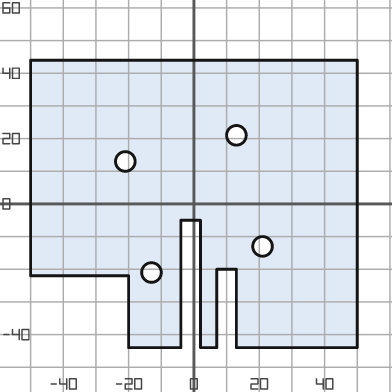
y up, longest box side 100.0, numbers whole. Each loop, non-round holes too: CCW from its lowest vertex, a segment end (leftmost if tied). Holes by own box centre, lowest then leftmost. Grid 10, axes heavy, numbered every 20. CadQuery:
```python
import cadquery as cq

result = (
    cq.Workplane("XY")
    .moveTo(-20.0, -44.0)
    .lineTo(-4.0, -44.0)
    .lineTo(-4.0, -5.0)
    .lineTo(2.0, -5.0)
    .lineTo(2.0, -44.0)
    .lineTo(7.0, -44.0)
    .lineTo(7.0, -20.0)
    .lineTo(13.0, -20.0)
    .lineTo(13.0, -44.0)
    .lineTo(50.0, -44.0)
    .lineTo(50.0, 44.0)
    .lineTo(-50.0, 44.0)
    .lineTo(-50.0, -22.0)
    .lineTo(-20.0, -22.0)
    .close()
    .moveTo(-13.0, -21.0)
    .circle(3.0)
    .moveTo(21.0, -13.0)
    .circle(3.0)
    .moveTo(-21.0, 13.0)
    .circle(3.0)
    .moveTo(13.0, 21.0)
    .circle(3.0)
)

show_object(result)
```